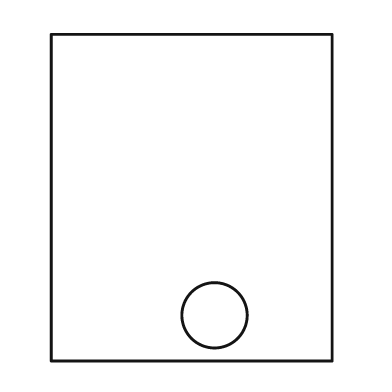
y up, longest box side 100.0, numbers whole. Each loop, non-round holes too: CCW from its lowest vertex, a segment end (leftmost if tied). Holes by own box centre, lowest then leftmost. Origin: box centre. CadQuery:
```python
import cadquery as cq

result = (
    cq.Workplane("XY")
    .moveTo(-43.0, -50.0)
    .lineTo(43.0, -50.0)
    .lineTo(43.0, 50.0)
    .lineTo(-43.0, 50.0)
    .close()
    .moveTo(7.0, -36.0)
    .circle(10.0)
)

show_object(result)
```